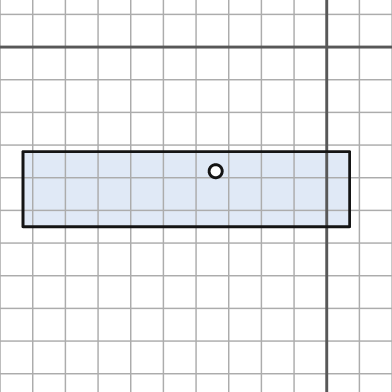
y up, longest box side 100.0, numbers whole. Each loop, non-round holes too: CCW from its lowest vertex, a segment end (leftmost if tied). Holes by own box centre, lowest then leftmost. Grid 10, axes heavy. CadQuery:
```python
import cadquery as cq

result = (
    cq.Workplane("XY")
    .moveTo(-93.0, -55.0)
    .lineTo(7.0, -55.0)
    .lineTo(7.0, -32.0)
    .lineTo(-93.0, -32.0)
    .close()
    .moveTo(-34.0, -38.0)
    .circle(2.0)
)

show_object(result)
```